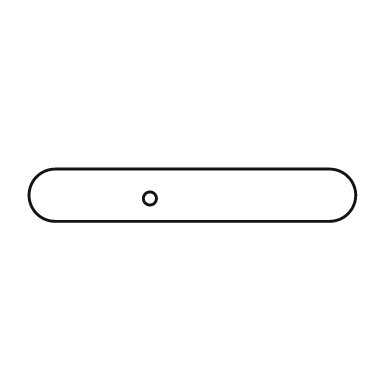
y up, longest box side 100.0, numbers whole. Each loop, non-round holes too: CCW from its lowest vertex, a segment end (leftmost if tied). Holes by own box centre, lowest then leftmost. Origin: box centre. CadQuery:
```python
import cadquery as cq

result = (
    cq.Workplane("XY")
    .moveTo(-42.0, -8.0)
    .lineTo(42.0, -8.0)
    .threePointArc((50.0, 0.0), (42.0, 8.0))
    .lineTo(-42.0, 8.0)
    .threePointArc((-50.0, 0.0), (-42.0, -8.0))
    .close()
    .moveTo(-13.0, -1.0)
    .circle(2.0)
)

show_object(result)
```